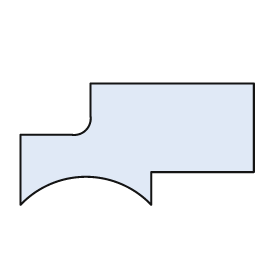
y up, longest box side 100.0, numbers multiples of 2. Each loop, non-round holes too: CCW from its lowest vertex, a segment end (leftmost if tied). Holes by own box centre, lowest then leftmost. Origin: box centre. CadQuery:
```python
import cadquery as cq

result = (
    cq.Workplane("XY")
    .moveTo(-50.0, -26.0)
    .threePointArc((-22.0, -14.0), (6.0, -26.0))
    .lineTo(6.0, -12.0)
    .lineTo(50.0, -12.0)
    .lineTo(50.0, 26.0)
    .lineTo(-20.0, 26.0)
    .lineTo(-20.0, 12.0)
    .threePointArc((-22.0, 6.0), (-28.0, 4.0))
    .lineTo(-50.0, 4.0)
    .close()
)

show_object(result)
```